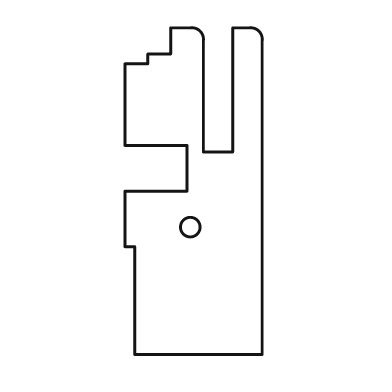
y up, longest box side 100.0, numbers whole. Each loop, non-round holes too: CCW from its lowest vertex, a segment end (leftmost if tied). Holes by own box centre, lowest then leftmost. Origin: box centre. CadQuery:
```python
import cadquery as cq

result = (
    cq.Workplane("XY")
    .moveTo(-18.0, -50.0)
    .lineTo(21.0, -50.0)
    .lineTo(21.0, 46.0)
    .threePointArc((20.0, 49.0), (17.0, 50.0))
    .lineTo(12.0, 50.0)
    .lineTo(12.0, 12.0)
    .lineTo(3.0, 12.0)
    .lineTo(3.0, 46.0)
    .threePointArc((2.0, 49.0), (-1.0, 50.0))
    .lineTo(-7.0, 50.0)
    .lineTo(-7.0, 42.0)
    .lineTo(-14.0, 42.0)
    .lineTo(-14.0, 39.0)
    .lineTo(-21.0, 39.0)
    .lineTo(-21.0, 14.0)
    .lineTo(-2.0, 14.0)
    .lineTo(-2.0, 0.0)
    .lineTo(-21.0, 0.0)
    .lineTo(-21.0, -17.0)
    .lineTo(-18.0, -17.0)
    .close()
    .moveTo(-1.0, -11.0)
    .circle(3.0)
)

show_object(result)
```